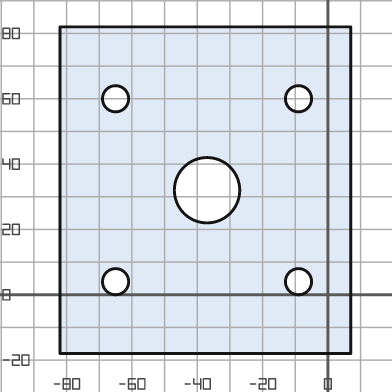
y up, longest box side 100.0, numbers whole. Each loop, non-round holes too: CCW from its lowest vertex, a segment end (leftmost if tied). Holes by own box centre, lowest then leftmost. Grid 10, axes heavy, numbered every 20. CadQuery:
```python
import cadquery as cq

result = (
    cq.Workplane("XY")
    .moveTo(-82.0, -18.0)
    .lineTo(7.0, -18.0)
    .lineTo(7.0, 82.0)
    .lineTo(-82.0, 82.0)
    .close()
    .moveTo(-65.0, 4.0)
    .circle(4.0)
    .moveTo(-9.0, 4.0)
    .circle(4.0)
    .moveTo(-37.0, 32.0)
    .circle(10.0)
    .moveTo(-65.0, 60.0)
    .circle(4.0)
    .moveTo(-9.0, 60.0)
    .circle(4.0)
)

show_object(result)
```